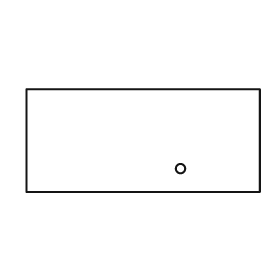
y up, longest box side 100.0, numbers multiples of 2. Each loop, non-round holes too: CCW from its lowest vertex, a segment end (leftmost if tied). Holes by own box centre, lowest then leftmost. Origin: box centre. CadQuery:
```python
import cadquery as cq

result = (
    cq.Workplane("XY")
    .moveTo(-50.0, -22.0)
    .lineTo(50.0, -22.0)
    .lineTo(50.0, 22.0)
    .lineTo(-50.0, 22.0)
    .close()
    .moveTo(16.0, -12.0)
    .circle(2.0)
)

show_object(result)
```